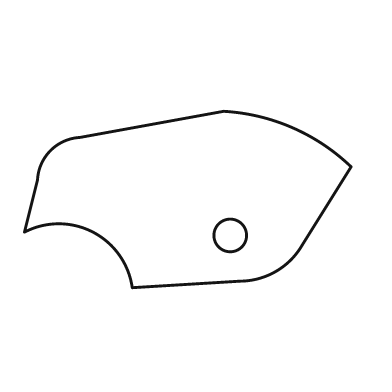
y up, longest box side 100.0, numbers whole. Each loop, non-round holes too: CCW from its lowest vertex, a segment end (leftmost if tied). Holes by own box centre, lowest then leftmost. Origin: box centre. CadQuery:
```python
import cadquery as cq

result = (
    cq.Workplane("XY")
    .moveTo(-17.0, -27.0)
    .lineTo(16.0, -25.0)
    .threePointArc((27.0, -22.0), (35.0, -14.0))
    .lineTo(50.0, 10.0)
    .threePointArc((32.0, 22.0), (11.0, 27.0))
    .lineTo(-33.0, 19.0)
    .threePointArc((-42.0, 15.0), (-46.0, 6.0))
    .lineTo(-50.0, -10.0)
    .threePointArc((-29.0, -10.0), (-17.0, -27.0))
    .close()
    .moveTo(13.0, -11.0)
    .circle(5.0)
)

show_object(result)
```